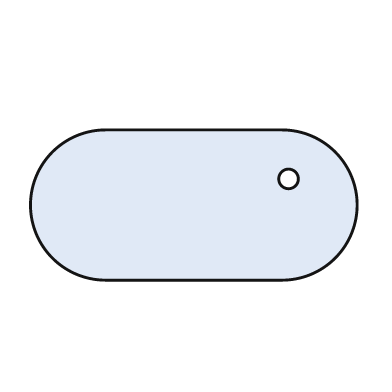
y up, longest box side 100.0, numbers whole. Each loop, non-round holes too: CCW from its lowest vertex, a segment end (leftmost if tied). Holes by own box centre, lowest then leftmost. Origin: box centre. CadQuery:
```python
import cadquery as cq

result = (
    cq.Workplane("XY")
    .moveTo(-27.0, -23.0)
    .lineTo(27.0, -23.0)
    .threePointArc((50.0, 0.0), (27.0, 23.0))
    .lineTo(-27.0, 23.0)
    .threePointArc((-50.0, 0.0), (-27.0, -23.0))
    .close()
    .moveTo(29.0, 8.0)
    .circle(3.0)
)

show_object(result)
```